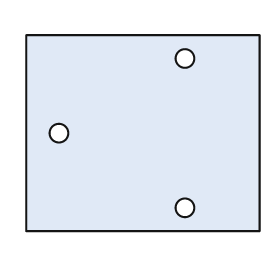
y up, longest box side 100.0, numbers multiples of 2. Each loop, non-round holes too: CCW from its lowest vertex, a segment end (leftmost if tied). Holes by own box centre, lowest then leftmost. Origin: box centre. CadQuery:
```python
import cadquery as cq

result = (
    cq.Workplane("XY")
    .moveTo(-50.0, -42.0)
    .lineTo(50.0, -42.0)
    .lineTo(50.0, 42.0)
    .lineTo(-50.0, 42.0)
    .close()
    .moveTo(18.0, -32.0)
    .circle(4.0)
    .moveTo(-36.0, 0.0)
    .circle(4.0)
    .moveTo(18.0, 32.0)
    .circle(4.0)
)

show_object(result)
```